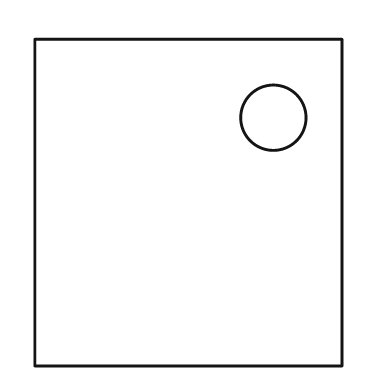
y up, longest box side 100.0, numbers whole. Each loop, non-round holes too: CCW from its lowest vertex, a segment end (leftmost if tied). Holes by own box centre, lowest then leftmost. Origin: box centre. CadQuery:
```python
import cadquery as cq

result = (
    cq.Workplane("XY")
    .moveTo(-47.0, -50.0)
    .lineTo(47.0, -50.0)
    .lineTo(47.0, 50.0)
    .lineTo(-47.0, 50.0)
    .close()
    .moveTo(26.0, 26.0)
    .circle(10.0)
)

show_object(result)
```